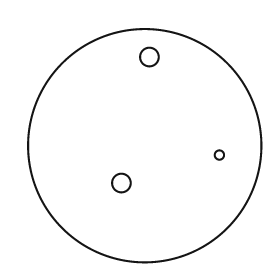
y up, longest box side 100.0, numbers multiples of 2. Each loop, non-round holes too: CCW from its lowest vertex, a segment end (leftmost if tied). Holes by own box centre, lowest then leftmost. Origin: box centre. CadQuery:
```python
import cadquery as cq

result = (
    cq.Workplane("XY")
    .moveTo(0.0, 0.0)
    .circle(50.0)
    .moveTo(-10.0, -16.0)
    .circle(4.0)
    .moveTo(32.0, -4.0)
    .circle(2.0)
    .moveTo(2.0, 38.0)
    .circle(4.0)
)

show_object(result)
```